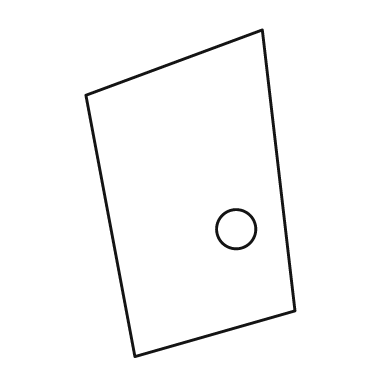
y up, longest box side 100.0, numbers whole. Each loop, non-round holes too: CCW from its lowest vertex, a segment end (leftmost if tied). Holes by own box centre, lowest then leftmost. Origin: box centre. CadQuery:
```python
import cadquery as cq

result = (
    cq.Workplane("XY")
    .moveTo(-17.0, -50.0)
    .lineTo(32.0, -36.0)
    .lineTo(22.0, 50.0)
    .lineTo(-32.0, 30.0)
    .close()
    .moveTo(14.0, -11.0)
    .circle(6.0)
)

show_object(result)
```